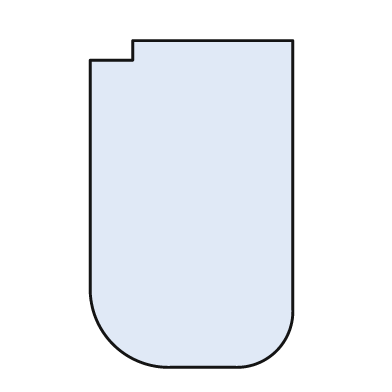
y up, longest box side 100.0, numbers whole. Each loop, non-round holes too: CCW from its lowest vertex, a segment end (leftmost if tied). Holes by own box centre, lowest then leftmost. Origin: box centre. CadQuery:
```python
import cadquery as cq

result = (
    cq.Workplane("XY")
    .moveTo(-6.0, -50.0)
    .lineTo(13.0, -50.0)
    .threePointArc((26.0, -45.0), (31.0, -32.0))
    .lineTo(31.0, 50.0)
    .lineTo(-18.0, 50.0)
    .lineTo(-18.0, 44.0)
    .lineTo(-31.0, 44.0)
    .lineTo(-31.0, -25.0)
    .threePointArc((-24.0, -43.0), (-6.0, -50.0))
    .close()
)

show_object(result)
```